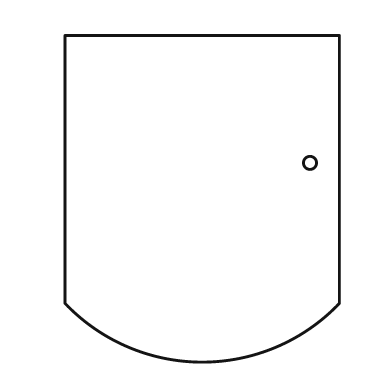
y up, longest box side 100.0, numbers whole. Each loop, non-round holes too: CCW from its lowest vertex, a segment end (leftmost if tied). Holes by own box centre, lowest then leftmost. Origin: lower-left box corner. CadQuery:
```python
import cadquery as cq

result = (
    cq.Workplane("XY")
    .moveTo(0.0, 18.0)
    .threePointArc((42.0, 0.0), (84.0, 18.0))
    .lineTo(84.0, 100.0)
    .lineTo(0.0, 100.0)
    .close()
    .moveTo(75.0, 61.0)
    .circle(2.0)
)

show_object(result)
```